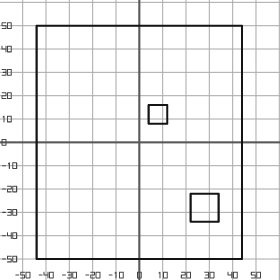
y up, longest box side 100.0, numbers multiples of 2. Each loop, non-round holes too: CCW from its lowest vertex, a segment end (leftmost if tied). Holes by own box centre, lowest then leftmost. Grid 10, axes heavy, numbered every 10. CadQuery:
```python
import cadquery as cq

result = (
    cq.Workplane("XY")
    .moveTo(-44.0, -50.0)
    .lineTo(44.0, -50.0)
    .lineTo(44.0, 50.0)
    .lineTo(-44.0, 50.0)
    .close()
    .moveTo(22.0, -34.0)
    .lineTo(34.0, -34.0)
    .lineTo(34.0, -22.0)
    .lineTo(22.0, -22.0)
    .close()
    .moveTo(4.0, 8.0)
    .lineTo(12.0, 8.0)
    .lineTo(12.0, 16.0)
    .lineTo(4.0, 16.0)
    .close()
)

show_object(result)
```